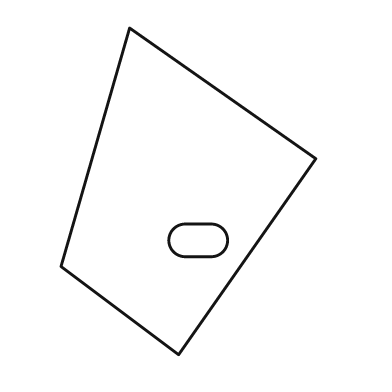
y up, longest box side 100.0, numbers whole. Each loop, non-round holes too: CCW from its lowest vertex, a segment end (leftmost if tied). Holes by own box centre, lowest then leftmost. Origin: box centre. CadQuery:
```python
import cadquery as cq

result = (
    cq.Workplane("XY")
    .moveTo(-3.0, -50.0)
    .lineTo(39.0, 10.0)
    .lineTo(-18.0, 50.0)
    .lineTo(-39.0, -23.0)
    .close()
    .moveTo(-1.0, -20.0)
    .lineTo(7.0, -20.0)
    .threePointArc((12.0, -15.0), (7.0, -10.0))
    .lineTo(-1.0, -10.0)
    .threePointArc((-6.0, -15.0), (-1.0, -20.0))
    .close()
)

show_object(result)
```